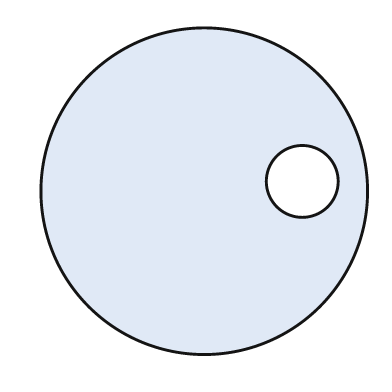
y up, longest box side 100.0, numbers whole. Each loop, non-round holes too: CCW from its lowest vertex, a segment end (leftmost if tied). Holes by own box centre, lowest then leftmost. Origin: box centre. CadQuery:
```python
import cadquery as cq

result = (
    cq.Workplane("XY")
    .moveTo(0.0, 0.0)
    .circle(50.0)
    .moveTo(30.0, 3.0)
    .circle(11.0)
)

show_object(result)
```